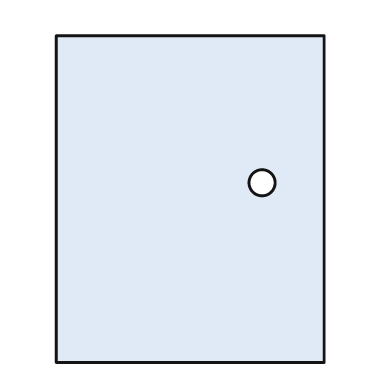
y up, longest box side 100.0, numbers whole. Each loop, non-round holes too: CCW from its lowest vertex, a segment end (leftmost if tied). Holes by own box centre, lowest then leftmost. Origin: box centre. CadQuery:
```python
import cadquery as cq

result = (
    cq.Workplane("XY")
    .moveTo(-41.0, -50.0)
    .lineTo(41.0, -50.0)
    .lineTo(41.0, 50.0)
    .lineTo(-41.0, 50.0)
    .close()
    .moveTo(22.0, 5.0)
    .circle(4.0)
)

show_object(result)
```